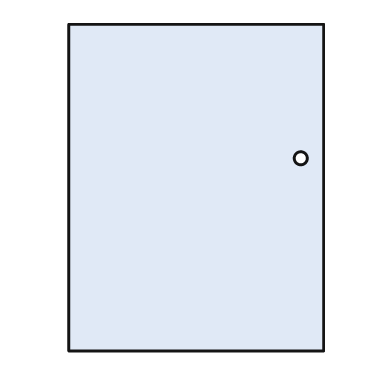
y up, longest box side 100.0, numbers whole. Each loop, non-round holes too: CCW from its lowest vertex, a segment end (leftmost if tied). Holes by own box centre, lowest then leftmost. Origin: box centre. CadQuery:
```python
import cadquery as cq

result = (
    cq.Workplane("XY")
    .moveTo(-39.0, -50.0)
    .lineTo(39.0, -50.0)
    .lineTo(39.0, 50.0)
    .lineTo(-39.0, 50.0)
    .close()
    .moveTo(32.0, 9.0)
    .circle(2.0)
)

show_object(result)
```